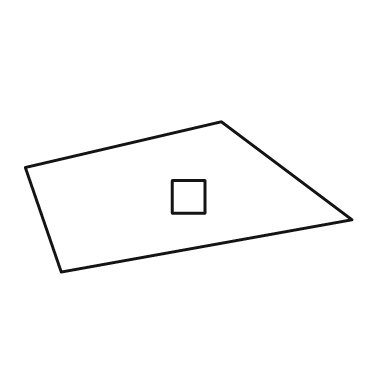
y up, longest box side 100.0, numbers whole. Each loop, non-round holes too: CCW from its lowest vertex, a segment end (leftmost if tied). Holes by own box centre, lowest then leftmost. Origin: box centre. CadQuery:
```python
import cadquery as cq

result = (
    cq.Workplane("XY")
    .moveTo(-39.0, -23.0)
    .lineTo(50.0, -7.0)
    .lineTo(10.0, 23.0)
    .lineTo(-50.0, 9.0)
    .close()
    .moveTo(-5.0, -5.0)
    .lineTo(5.0, -5.0)
    .lineTo(5.0, 5.0)
    .lineTo(-5.0, 5.0)
    .close()
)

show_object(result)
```